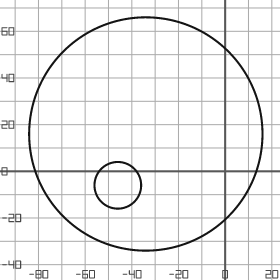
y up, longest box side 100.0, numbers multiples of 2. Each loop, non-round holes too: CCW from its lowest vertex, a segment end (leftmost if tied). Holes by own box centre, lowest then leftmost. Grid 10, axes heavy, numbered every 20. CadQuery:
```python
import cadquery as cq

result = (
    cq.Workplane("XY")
    .moveTo(-34.0, 16.0)
    .circle(50.0)
    .moveTo(-46.0, -6.0)
    .circle(10.0)
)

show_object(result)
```